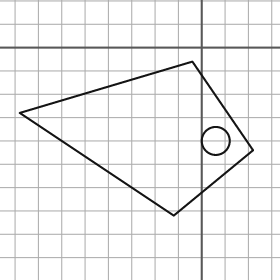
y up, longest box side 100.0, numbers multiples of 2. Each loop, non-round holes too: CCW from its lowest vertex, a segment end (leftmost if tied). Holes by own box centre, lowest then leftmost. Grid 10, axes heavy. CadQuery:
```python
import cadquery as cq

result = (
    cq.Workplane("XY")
    .moveTo(-12.0, -72.0)
    .lineTo(22.0, -44.0)
    .lineTo(-4.0, -6.0)
    .lineTo(-78.0, -28.0)
    .close()
    .moveTo(6.0, -40.0)
    .circle(6.0)
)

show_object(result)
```